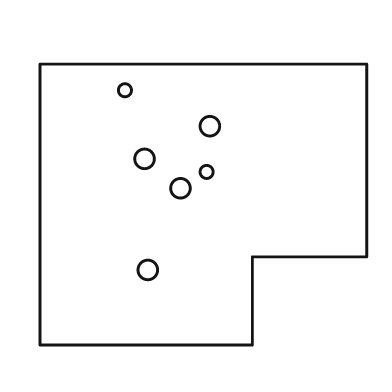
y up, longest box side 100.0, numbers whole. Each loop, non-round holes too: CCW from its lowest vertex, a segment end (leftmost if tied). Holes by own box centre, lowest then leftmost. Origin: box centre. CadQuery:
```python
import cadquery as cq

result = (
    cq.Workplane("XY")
    .moveTo(-50.0, -43.0)
    .lineTo(15.0, -43.0)
    .lineTo(15.0, -16.0)
    .lineTo(50.0, -16.0)
    .lineTo(50.0, 43.0)
    .lineTo(-50.0, 43.0)
    .close()
    .moveTo(-17.0, -20.0)
    .circle(3.0)
    .moveTo(-7.0, 5.0)
    .circle(3.0)
    .moveTo(1.0, 10.0)
    .circle(2.0)
    .moveTo(-18.0, 14.0)
    .circle(3.0)
    .moveTo(2.0, 24.0)
    .circle(3.0)
    .moveTo(-24.0, 35.0)
    .circle(2.0)
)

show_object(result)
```